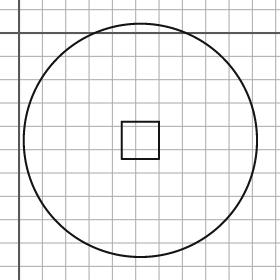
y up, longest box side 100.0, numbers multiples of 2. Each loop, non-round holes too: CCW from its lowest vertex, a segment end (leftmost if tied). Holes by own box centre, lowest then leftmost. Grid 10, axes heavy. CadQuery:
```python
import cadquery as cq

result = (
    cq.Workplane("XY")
    .moveTo(52.0, -46.0)
    .circle(50.0)
    .moveTo(44.0, -54.0)
    .lineTo(60.0, -54.0)
    .lineTo(60.0, -38.0)
    .lineTo(44.0, -38.0)
    .close()
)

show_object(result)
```